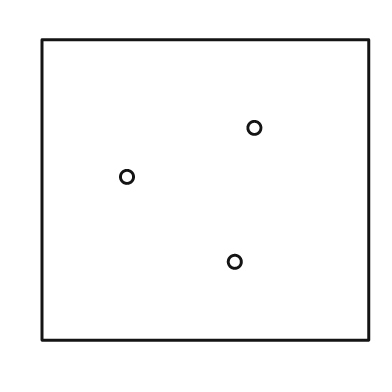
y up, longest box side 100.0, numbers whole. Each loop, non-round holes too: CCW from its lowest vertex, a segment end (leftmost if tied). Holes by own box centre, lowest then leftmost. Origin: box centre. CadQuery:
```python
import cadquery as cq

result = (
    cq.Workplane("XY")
    .moveTo(-50.0, -46.0)
    .lineTo(50.0, -46.0)
    .lineTo(50.0, 46.0)
    .lineTo(-50.0, 46.0)
    .close()
    .moveTo(9.0, -22.0)
    .circle(2.0)
    .moveTo(-24.0, 4.0)
    .circle(2.0)
    .moveTo(15.0, 19.0)
    .circle(2.0)
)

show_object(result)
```